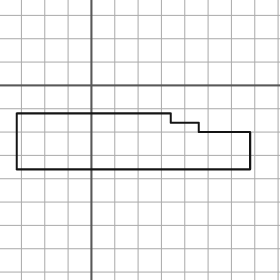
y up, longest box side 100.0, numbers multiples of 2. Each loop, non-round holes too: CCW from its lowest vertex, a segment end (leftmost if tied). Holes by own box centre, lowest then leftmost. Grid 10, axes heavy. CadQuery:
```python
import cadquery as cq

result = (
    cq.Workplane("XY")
    .moveTo(-32.0, -36.0)
    .lineTo(68.0, -36.0)
    .lineTo(68.0, -20.0)
    .lineTo(46.0, -20.0)
    .lineTo(46.0, -16.0)
    .lineTo(34.0, -16.0)
    .lineTo(34.0, -12.0)
    .lineTo(-32.0, -12.0)
    .close()
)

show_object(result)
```